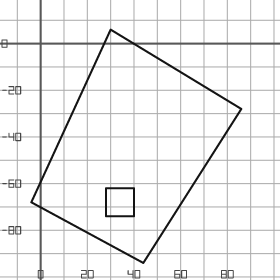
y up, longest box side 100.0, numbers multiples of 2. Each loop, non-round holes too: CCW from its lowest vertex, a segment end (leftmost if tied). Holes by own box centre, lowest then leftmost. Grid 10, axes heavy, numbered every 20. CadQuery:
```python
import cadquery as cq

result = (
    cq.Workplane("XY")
    .moveTo(44.0, -94.0)
    .lineTo(86.0, -28.0)
    .lineTo(30.0, 6.0)
    .lineTo(-4.0, -68.0)
    .close()
    .moveTo(28.0, -74.0)
    .lineTo(40.0, -74.0)
    .lineTo(40.0, -62.0)
    .lineTo(28.0, -62.0)
    .close()
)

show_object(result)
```